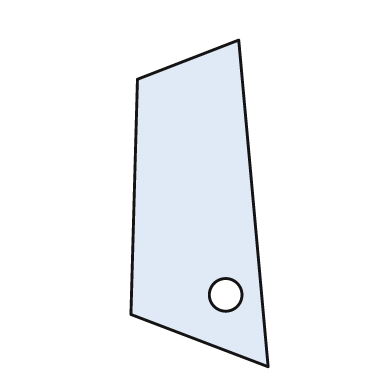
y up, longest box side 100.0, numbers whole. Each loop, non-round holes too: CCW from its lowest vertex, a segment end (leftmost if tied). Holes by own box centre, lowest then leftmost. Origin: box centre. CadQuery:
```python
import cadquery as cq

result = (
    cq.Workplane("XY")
    .moveTo(21.0, -50.0)
    .lineTo(12.0, 50.0)
    .lineTo(-19.0, 38.0)
    .lineTo(-21.0, -34.0)
    .close()
    .moveTo(8.0, -28.0)
    .circle(5.0)
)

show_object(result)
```